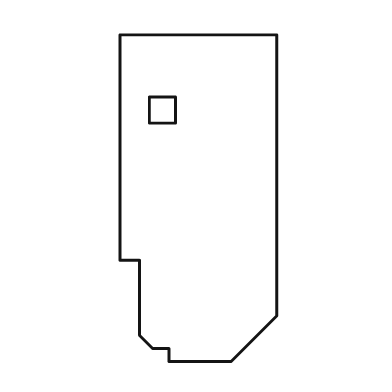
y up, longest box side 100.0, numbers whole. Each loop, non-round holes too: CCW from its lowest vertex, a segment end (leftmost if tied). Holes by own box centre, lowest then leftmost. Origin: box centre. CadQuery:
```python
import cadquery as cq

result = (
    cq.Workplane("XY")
    .moveTo(-9.0, -50.0)
    .lineTo(10.0, -50.0)
    .lineTo(24.0, -36.0)
    .lineTo(24.0, 50.0)
    .lineTo(-24.0, 50.0)
    .lineTo(-24.0, -19.0)
    .lineTo(-18.0, -19.0)
    .lineTo(-18.0, -42.0)
    .lineTo(-14.0, -46.0)
    .lineTo(-9.0, -46.0)
    .close()
    .moveTo(-15.0, 23.0)
    .lineTo(-7.0, 23.0)
    .lineTo(-7.0, 31.0)
    .lineTo(-15.0, 31.0)
    .close()
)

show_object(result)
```